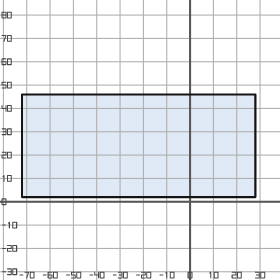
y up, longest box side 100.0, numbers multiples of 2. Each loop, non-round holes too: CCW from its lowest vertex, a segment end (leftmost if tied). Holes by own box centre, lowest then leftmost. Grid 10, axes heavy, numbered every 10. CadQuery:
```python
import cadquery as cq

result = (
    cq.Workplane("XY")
    .moveTo(-72.0, 2.0)
    .lineTo(28.0, 2.0)
    .lineTo(28.0, 46.0)
    .lineTo(-72.0, 46.0)
    .close()
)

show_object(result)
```